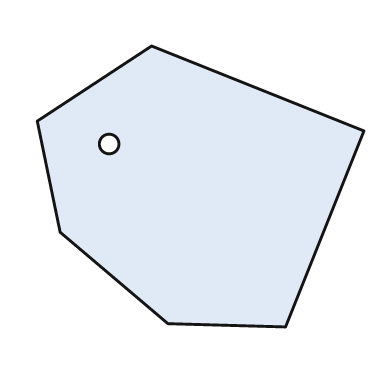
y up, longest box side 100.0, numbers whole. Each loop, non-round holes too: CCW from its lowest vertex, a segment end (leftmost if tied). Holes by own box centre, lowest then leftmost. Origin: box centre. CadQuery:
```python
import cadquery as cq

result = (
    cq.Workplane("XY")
    .moveTo(26.0, -43.0)
    .lineTo(50.0, 17.0)
    .lineTo(-15.0, 43.0)
    .lineTo(-50.0, 20.0)
    .lineTo(-43.0, -14.0)
    .lineTo(-10.0, -42.0)
    .close()
    .moveTo(-28.0, 13.0)
    .circle(3.0)
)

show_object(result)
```